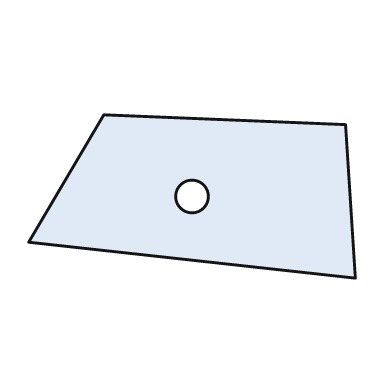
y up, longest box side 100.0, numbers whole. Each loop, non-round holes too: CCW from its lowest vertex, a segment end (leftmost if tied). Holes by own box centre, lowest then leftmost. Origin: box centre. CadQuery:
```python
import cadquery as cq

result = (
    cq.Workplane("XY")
    .moveTo(50.0, -25.0)
    .lineTo(47.0, 22.0)
    .lineTo(-27.0, 25.0)
    .lineTo(-50.0, -14.0)
    .close()
    .moveTo(0.0, 0.0)
    .circle(5.0)
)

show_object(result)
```